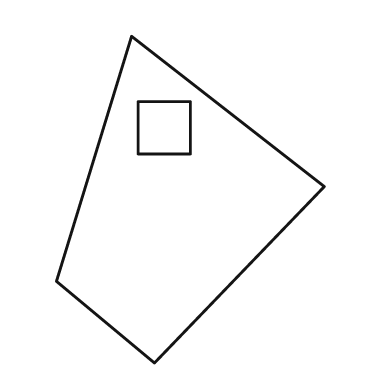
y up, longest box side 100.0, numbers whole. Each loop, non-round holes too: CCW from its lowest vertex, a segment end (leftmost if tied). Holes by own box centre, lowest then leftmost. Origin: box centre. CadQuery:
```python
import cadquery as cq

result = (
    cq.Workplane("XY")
    .moveTo(-11.0, -50.0)
    .lineTo(41.0, 4.0)
    .lineTo(-18.0, 50.0)
    .lineTo(-41.0, -25.0)
    .close()
    .moveTo(-16.0, 14.0)
    .lineTo(0.0, 14.0)
    .lineTo(0.0, 30.0)
    .lineTo(-16.0, 30.0)
    .close()
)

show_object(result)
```